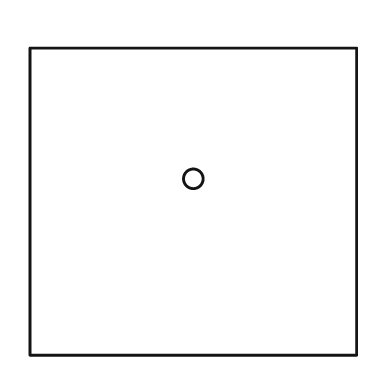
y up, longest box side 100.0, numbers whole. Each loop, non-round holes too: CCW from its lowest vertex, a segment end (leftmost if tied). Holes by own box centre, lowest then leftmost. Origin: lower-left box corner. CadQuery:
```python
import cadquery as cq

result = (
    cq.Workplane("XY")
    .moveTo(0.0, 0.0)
    .lineTo(100.0, 0.0)
    .lineTo(100.0, 94.0)
    .lineTo(0.0, 94.0)
    .close()
    .moveTo(50.0, 54.0)
    .circle(3.0)
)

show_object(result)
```